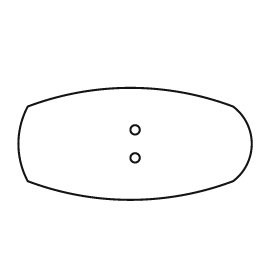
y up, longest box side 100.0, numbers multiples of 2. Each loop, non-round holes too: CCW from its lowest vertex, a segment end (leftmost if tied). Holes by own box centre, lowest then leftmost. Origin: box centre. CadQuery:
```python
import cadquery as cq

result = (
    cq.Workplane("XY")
    .moveTo(-46.0, -16.0)
    .threePointArc((-2.0, -24.0), (42.0, -16.0))
    .threePointArc((50.0, 0.0), (42.0, 16.0))
    .threePointArc((-2.0, 24.0), (-46.0, 16.0))
    .threePointArc((-50.0, 0.0), (-46.0, -16.0))
    .close()
    .moveTo(0.0, -6.0)
    .circle(2.0)
    .moveTo(0.0, 6.0)
    .circle(2.0)
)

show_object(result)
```